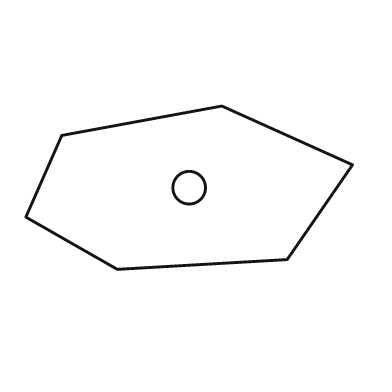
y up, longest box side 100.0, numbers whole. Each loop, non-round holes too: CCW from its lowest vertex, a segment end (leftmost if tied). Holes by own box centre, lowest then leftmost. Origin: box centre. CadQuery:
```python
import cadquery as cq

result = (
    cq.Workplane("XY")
    .moveTo(-22.0, -25.0)
    .lineTo(30.0, -22.0)
    .lineTo(50.0, 7.0)
    .lineTo(10.0, 25.0)
    .lineTo(-39.0, 16.0)
    .lineTo(-50.0, -9.0)
    .close()
    .moveTo(0.0, 0.0)
    .circle(5.0)
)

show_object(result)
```